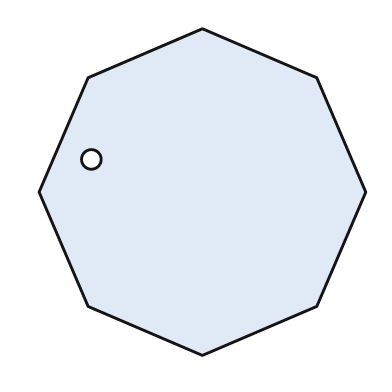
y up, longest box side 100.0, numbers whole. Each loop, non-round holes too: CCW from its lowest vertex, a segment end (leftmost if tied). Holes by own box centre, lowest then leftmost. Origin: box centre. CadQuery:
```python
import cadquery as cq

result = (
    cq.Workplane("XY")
    .moveTo(0.0, -50.0)
    .lineTo(35.0, -35.0)
    .lineTo(50.0, 0.0)
    .lineTo(35.0, 35.0)
    .lineTo(0.0, 50.0)
    .lineTo(-35.0, 35.0)
    .lineTo(-50.0, 0.0)
    .lineTo(-35.0, -35.0)
    .close()
    .moveTo(-34.0, 10.0)
    .circle(3.0)
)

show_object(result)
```